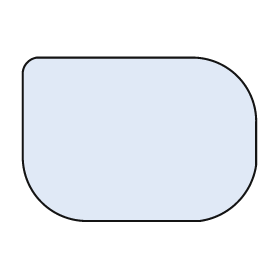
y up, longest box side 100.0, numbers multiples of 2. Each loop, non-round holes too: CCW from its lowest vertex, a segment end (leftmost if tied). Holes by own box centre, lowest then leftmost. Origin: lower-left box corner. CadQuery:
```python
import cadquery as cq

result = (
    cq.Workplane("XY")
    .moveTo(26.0, 0.0)
    .lineTo(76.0, 0.0)
    .threePointArc((92.0, 8.0), (100.0, 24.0))
    .lineTo(100.0, 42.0)
    .threePointArc((92.0, 62.0), (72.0, 70.0))
    .lineTo(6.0, 70.0)
    .threePointArc((2.0, 68.0), (0.0, 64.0))
    .lineTo(0.0, 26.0)
    .threePointArc((8.0, 8.0), (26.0, 0.0))
    .close()
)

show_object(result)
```